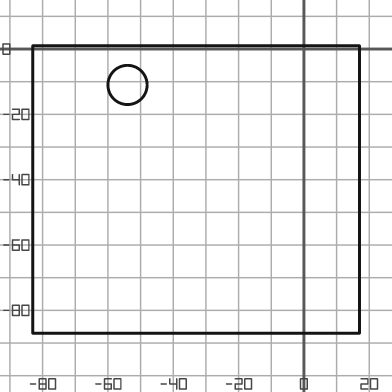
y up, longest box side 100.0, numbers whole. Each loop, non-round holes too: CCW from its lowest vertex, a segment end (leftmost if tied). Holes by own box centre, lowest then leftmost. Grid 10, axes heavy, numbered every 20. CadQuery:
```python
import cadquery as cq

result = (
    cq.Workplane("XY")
    .moveTo(-83.0, -87.0)
    .lineTo(17.0, -87.0)
    .lineTo(17.0, 1.0)
    .lineTo(-83.0, 1.0)
    .close()
    .moveTo(-54.0, -11.0)
    .circle(6.0)
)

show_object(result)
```